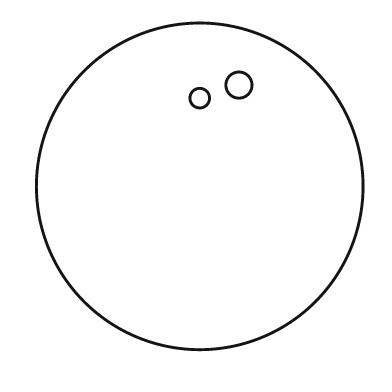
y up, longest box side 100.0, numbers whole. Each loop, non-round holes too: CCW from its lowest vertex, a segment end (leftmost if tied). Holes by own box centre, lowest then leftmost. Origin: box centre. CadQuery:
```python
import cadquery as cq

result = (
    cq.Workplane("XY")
    .moveTo(0.0, 0.0)
    .circle(50.0)
    .moveTo(0.0, 27.0)
    .circle(3.0)
    .moveTo(12.0, 31.0)
    .circle(4.0)
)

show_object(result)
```